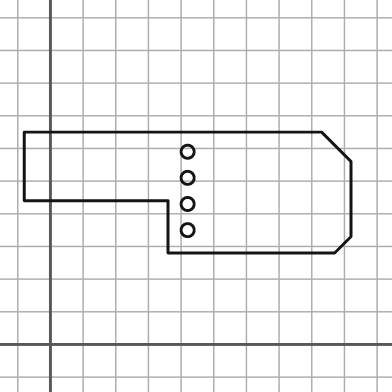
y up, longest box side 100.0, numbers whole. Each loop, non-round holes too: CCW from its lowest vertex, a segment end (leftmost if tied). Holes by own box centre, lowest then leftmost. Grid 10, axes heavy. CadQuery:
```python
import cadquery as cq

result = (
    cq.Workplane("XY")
    .moveTo(36.0, 28.0)
    .lineTo(87.0, 28.0)
    .lineTo(92.0, 33.0)
    .lineTo(92.0, 56.0)
    .lineTo(83.0, 65.0)
    .lineTo(-8.0, 65.0)
    .lineTo(-8.0, 44.0)
    .lineTo(36.0, 44.0)
    .close()
    .moveTo(42.0, 35.0)
    .circle(2.0)
    .moveTo(42.0, 43.0)
    .circle(2.0)
    .moveTo(42.0, 51.0)
    .circle(2.0)
    .moveTo(42.0, 59.0)
    .circle(2.0)
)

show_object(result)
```